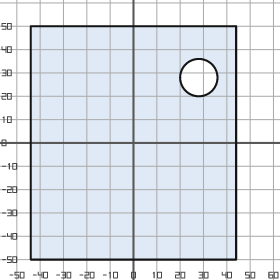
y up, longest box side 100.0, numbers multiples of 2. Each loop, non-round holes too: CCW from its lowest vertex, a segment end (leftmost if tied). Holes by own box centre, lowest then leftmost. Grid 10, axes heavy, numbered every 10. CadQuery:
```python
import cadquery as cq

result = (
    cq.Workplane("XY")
    .moveTo(-44.0, -50.0)
    .lineTo(44.0, -50.0)
    .lineTo(44.0, 50.0)
    .lineTo(-44.0, 50.0)
    .close()
    .moveTo(28.0, 28.0)
    .circle(8.0)
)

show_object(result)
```